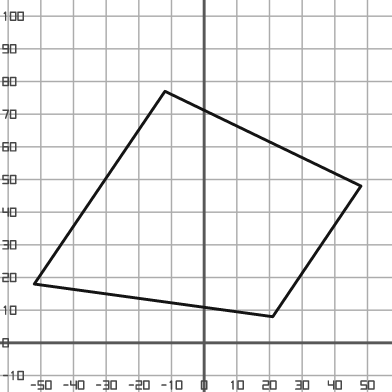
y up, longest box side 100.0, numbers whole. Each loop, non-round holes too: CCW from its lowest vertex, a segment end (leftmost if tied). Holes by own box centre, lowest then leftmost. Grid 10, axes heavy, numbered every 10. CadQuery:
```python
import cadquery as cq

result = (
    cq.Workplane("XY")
    .moveTo(21.0, 8.0)
    .lineTo(48.0, 48.0)
    .lineTo(-12.0, 77.0)
    .lineTo(-52.0, 18.0)
    .close()
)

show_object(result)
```